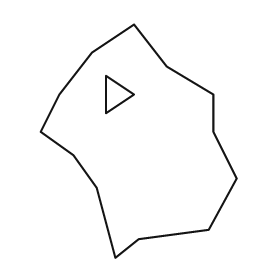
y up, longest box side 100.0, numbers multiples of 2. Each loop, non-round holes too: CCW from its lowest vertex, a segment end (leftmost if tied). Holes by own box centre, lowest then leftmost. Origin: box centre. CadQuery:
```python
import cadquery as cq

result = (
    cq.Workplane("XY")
    .moveTo(-10.0, -50.0)
    .lineTo(0.0, -42.0)
    .lineTo(30.0, -38.0)
    .lineTo(42.0, -16.0)
    .lineTo(32.0, 4.0)
    .lineTo(32.0, 20.0)
    .lineTo(12.0, 32.0)
    .lineTo(-2.0, 50.0)
    .lineTo(-20.0, 38.0)
    .lineTo(-34.0, 20.0)
    .lineTo(-42.0, 4.0)
    .lineTo(-28.0, -6.0)
    .lineTo(-18.0, -20.0)
    .close()
    .moveTo(-14.0, 12.0)
    .lineTo(-2.0, 20.0)
    .lineTo(-14.0, 28.0)
    .close()
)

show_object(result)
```